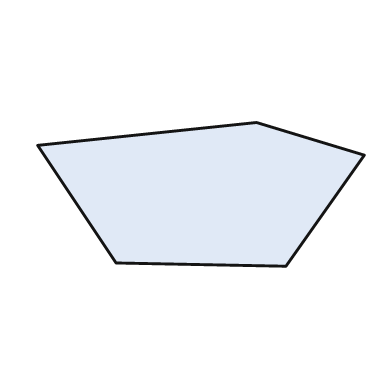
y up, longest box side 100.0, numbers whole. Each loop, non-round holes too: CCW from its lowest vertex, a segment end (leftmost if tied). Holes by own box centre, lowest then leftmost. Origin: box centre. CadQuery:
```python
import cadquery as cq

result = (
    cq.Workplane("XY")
    .moveTo(26.0, -22.0)
    .lineTo(50.0, 12.0)
    .lineTo(17.0, 22.0)
    .lineTo(-50.0, 15.0)
    .lineTo(-26.0, -21.0)
    .close()
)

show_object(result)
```